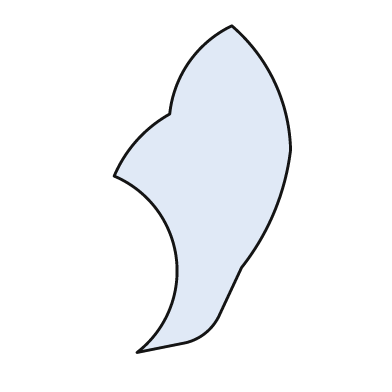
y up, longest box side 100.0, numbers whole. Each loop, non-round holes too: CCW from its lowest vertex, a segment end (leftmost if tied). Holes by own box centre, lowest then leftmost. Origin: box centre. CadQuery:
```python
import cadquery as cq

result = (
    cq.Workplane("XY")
    .moveTo(-20.0, -50.0)
    .lineTo(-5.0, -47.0)
    .threePointArc((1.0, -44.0), (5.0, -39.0))
    .lineTo(12.0, -24.0)
    .threePointArc((22.0, -7.0), (27.0, 12.0))
    .threePointArc((22.0, 33.0), (9.0, 50.0))
    .threePointArc((-4.0, 39.0), (-10.0, 23.0))
    .threePointArc((-20.0, 15.0), (-27.0, 4.0))
    .threePointArc((-8.0, -21.0), (-20.0, -50.0))
    .close()
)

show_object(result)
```